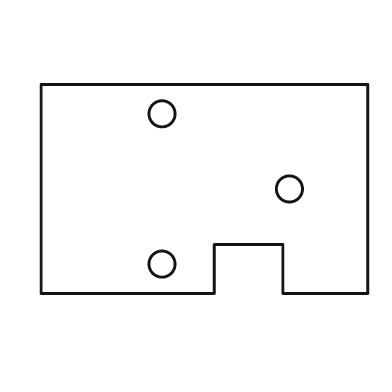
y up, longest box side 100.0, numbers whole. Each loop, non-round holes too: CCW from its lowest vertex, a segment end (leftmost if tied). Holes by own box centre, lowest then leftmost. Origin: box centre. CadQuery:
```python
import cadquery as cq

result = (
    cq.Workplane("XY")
    .moveTo(-50.0, -32.0)
    .lineTo(3.0, -32.0)
    .lineTo(3.0, -17.0)
    .lineTo(24.0, -17.0)
    .lineTo(24.0, -32.0)
    .lineTo(50.0, -32.0)
    .lineTo(50.0, 32.0)
    .lineTo(-50.0, 32.0)
    .close()
    .moveTo(-13.0, -23.0)
    .circle(4.0)
    .moveTo(26.0, 0.0)
    .circle(4.0)
    .moveTo(-13.0, 23.0)
    .circle(4.0)
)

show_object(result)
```